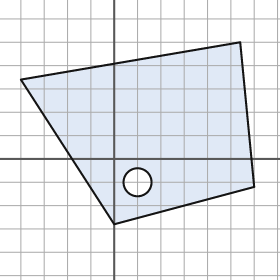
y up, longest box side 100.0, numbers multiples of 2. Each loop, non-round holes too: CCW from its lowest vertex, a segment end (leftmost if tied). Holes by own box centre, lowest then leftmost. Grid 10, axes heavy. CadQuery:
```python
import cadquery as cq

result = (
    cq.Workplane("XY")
    .moveTo(0.0, -28.0)
    .lineTo(60.0, -12.0)
    .lineTo(54.0, 50.0)
    .lineTo(-40.0, 34.0)
    .close()
    .moveTo(10.0, -10.0)
    .circle(6.0)
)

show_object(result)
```